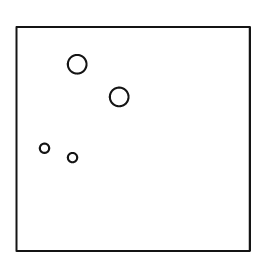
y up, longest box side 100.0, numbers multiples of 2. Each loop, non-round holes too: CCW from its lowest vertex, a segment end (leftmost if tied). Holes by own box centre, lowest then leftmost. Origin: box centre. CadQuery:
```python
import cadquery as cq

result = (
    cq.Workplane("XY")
    .moveTo(-50.0, -48.0)
    .lineTo(50.0, -48.0)
    .lineTo(50.0, 48.0)
    .lineTo(-50.0, 48.0)
    .close()
    .moveTo(-26.0, -8.0)
    .circle(2.0)
    .moveTo(-38.0, -4.0)
    .circle(2.0)
    .moveTo(-6.0, 18.0)
    .circle(4.0)
    .moveTo(-24.0, 32.0)
    .circle(4.0)
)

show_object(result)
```